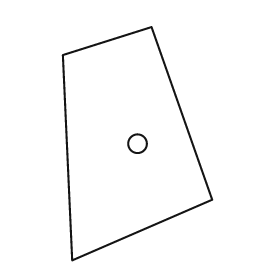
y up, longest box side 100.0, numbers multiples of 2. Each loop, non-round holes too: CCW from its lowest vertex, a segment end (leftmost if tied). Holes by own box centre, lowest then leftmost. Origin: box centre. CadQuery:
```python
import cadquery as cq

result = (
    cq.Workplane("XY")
    .moveTo(-28.0, -50.0)
    .lineTo(32.0, -24.0)
    .lineTo(6.0, 50.0)
    .lineTo(-32.0, 38.0)
    .close()
    .moveTo(0.0, 0.0)
    .circle(4.0)
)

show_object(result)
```